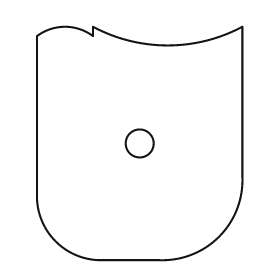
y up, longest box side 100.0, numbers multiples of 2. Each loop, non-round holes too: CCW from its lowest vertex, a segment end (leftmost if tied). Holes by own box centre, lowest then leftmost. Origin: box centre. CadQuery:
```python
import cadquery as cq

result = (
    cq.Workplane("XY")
    .moveTo(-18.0, -50.0)
    .lineTo(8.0, -50.0)
    .threePointArc((34.0, -40.0), (44.0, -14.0))
    .lineTo(44.0, 50.0)
    .threePointArc((12.0, 42.0), (-20.0, 50.0))
    .lineTo(-20.0, 46.0)
    .threePointArc((-32.0, 50.0), (-44.0, 46.0))
    .lineTo(-44.0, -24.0)
    .threePointArc((-36.0, -42.0), (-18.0, -50.0))
    .close()
    .moveTo(0.0, 0.0)
    .circle(6.0)
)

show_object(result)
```